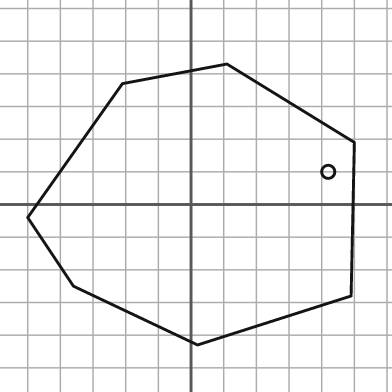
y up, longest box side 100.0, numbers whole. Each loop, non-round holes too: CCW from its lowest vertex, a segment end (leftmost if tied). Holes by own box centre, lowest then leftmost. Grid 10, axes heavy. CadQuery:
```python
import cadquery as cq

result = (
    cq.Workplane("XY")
    .moveTo(2.0, -43.0)
    .lineTo(49.0, -28.0)
    .lineTo(50.0, 19.0)
    .lineTo(11.0, 43.0)
    .lineTo(-21.0, 37.0)
    .lineTo(-50.0, -4.0)
    .lineTo(-36.0, -25.0)
    .close()
    .moveTo(42.0, 10.0)
    .circle(2.0)
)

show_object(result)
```